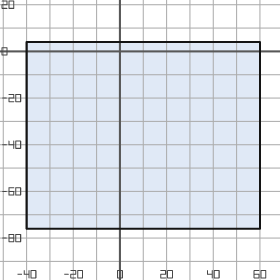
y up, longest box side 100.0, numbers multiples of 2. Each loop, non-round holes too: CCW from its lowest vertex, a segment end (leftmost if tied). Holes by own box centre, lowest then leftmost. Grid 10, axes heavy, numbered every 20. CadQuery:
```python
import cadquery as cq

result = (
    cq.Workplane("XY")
    .moveTo(-40.0, -76.0)
    .lineTo(60.0, -76.0)
    .lineTo(60.0, 4.0)
    .lineTo(-40.0, 4.0)
    .close()
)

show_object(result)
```